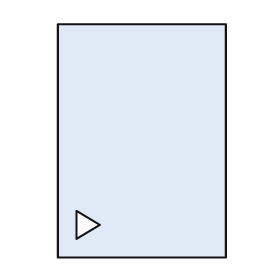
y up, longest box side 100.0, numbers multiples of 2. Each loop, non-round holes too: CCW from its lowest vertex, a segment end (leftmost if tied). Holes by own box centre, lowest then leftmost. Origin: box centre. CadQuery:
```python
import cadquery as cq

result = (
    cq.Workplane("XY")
    .moveTo(-36.0, -50.0)
    .lineTo(36.0, -50.0)
    .lineTo(36.0, 50.0)
    .lineTo(-36.0, 50.0)
    .close()
    .moveTo(-28.0, -42.0)
    .lineTo(-18.0, -36.0)
    .lineTo(-28.0, -30.0)
    .close()
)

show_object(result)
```